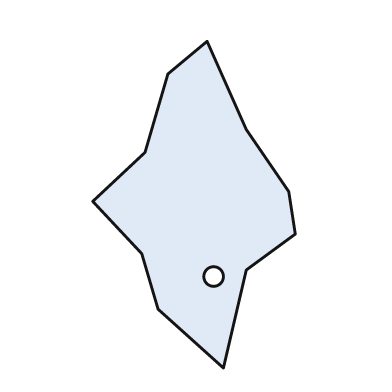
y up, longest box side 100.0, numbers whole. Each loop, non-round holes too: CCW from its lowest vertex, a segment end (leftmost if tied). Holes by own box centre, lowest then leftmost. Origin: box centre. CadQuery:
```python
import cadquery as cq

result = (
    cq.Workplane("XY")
    .moveTo(9.0, -50.0)
    .lineTo(16.0, -20.0)
    .lineTo(31.0, -9.0)
    .lineTo(29.0, 4.0)
    .lineTo(16.0, 23.0)
    .lineTo(4.0, 50.0)
    .lineTo(-8.0, 40.0)
    .lineTo(-15.0, 16.0)
    .lineTo(-31.0, 1.0)
    .lineTo(-16.0, -15.0)
    .lineTo(-11.0, -32.0)
    .close()
    .moveTo(6.0, -22.0)
    .circle(3.0)
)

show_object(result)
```